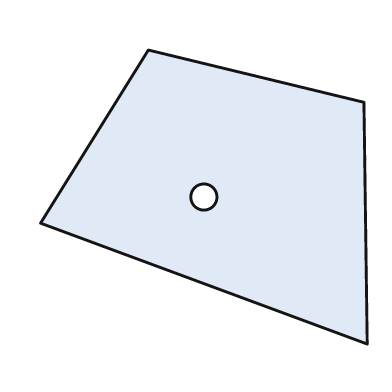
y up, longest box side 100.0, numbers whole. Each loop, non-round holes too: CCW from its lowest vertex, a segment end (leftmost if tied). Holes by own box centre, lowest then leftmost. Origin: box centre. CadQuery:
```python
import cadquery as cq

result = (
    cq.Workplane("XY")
    .moveTo(50.0, -45.0)
    .lineTo(49.0, 29.0)
    .lineTo(-17.0, 45.0)
    .lineTo(-50.0, -8.0)
    .close()
    .moveTo(0.0, 0.0)
    .circle(4.0)
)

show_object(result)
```